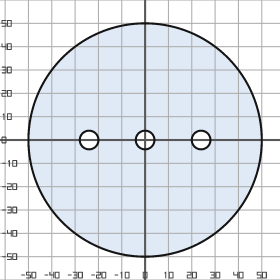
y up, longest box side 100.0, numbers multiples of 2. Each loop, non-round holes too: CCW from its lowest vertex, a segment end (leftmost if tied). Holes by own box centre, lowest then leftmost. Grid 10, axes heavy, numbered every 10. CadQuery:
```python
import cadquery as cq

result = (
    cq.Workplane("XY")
    .moveTo(0.0, 0.0)
    .circle(50.0)
    .moveTo(-24.0, 0.0)
    .circle(4.0)
    .moveTo(0.0, 0.0)
    .circle(4.0)
    .moveTo(24.0, 0.0)
    .circle(4.0)
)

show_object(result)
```